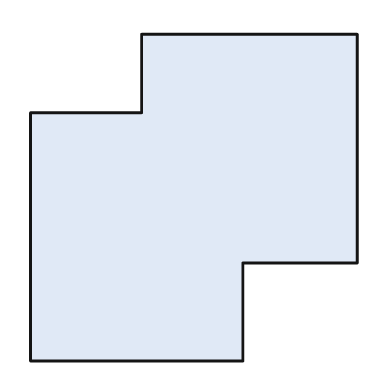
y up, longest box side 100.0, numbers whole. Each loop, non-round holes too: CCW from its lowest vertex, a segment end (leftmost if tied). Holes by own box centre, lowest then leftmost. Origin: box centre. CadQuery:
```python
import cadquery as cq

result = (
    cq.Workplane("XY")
    .moveTo(-50.0, -50.0)
    .lineTo(15.0, -50.0)
    .lineTo(15.0, -20.0)
    .lineTo(50.0, -20.0)
    .lineTo(50.0, 50.0)
    .lineTo(-16.0, 50.0)
    .lineTo(-16.0, 26.0)
    .lineTo(-50.0, 26.0)
    .close()
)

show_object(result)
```